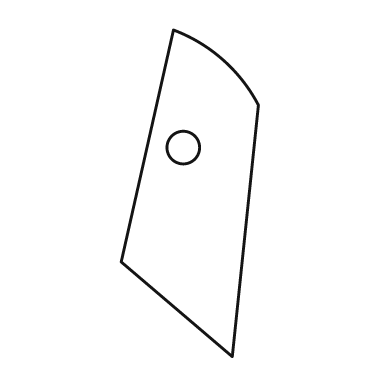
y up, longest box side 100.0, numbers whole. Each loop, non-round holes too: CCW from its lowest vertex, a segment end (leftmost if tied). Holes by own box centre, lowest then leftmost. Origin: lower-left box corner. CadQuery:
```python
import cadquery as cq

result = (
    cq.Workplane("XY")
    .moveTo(34.0, 0.0)
    .lineTo(42.0, 77.0)
    .threePointArc((31.0, 91.0), (16.0, 100.0))
    .lineTo(0.0, 29.0)
    .close()
    .moveTo(19.0, 64.0)
    .circle(5.0)
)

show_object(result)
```